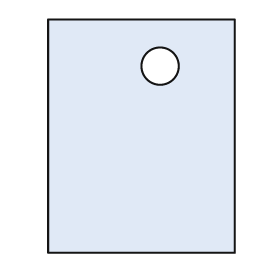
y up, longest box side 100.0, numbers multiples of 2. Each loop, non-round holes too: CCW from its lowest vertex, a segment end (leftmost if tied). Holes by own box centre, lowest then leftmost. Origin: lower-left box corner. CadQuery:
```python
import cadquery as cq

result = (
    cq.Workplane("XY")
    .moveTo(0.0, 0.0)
    .lineTo(80.0, 0.0)
    .lineTo(80.0, 100.0)
    .lineTo(0.0, 100.0)
    .close()
    .moveTo(48.0, 80.0)
    .circle(8.0)
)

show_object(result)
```